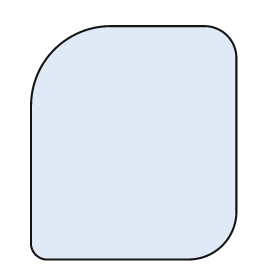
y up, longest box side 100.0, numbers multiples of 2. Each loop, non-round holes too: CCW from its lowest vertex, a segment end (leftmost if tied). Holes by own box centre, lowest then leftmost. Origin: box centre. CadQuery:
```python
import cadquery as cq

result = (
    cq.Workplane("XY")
    .moveTo(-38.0, -50.0)
    .lineTo(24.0, -50.0)
    .threePointArc((38.0, -44.0), (44.0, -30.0))
    .lineTo(44.0, 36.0)
    .threePointArc((40.0, 46.0), (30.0, 50.0))
    .lineTo(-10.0, 50.0)
    .threePointArc((-34.0, 40.0), (-44.0, 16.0))
    .lineTo(-44.0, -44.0)
    .threePointArc((-42.0, -48.0), (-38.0, -50.0))
    .close()
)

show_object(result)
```